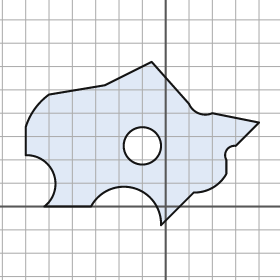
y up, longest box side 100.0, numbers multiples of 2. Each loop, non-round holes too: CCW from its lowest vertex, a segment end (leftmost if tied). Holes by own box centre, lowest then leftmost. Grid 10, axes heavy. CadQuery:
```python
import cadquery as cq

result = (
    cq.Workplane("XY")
    .moveTo(-2.0, -8.0)
    .lineTo(12.0, 6.0)
    .threePointArc((20.0, 8.0), (26.0, 14.0))
    .lineTo(26.0, 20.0)
    .threePointArc((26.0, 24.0), (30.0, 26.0))
    .lineTo(40.0, 36.0)
    .lineTo(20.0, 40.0)
    .threePointArc((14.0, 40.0), (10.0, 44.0))
    .lineTo(-6.0, 62.0)
    .lineTo(-26.0, 52.0)
    .lineTo(-50.0, 48.0)
    .threePointArc((-56.0, 42.0), (-60.0, 34.0))
    .lineTo(-60.0, 22.0)
    .threePointArc((-48.0, 14.0), (-52.0, 0.0))
    .lineTo(-32.0, 0.0)
    .threePointArc((-14.0, 8.0), (-2.0, -8.0))
    .close()
    .moveTo(-10.0, 26.0)
    .circle(8.0)
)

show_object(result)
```